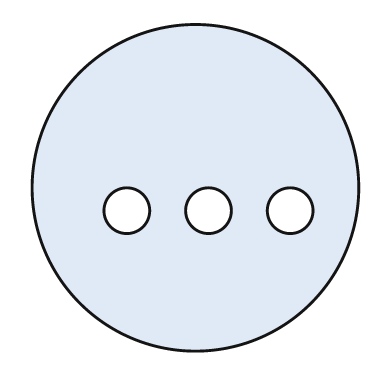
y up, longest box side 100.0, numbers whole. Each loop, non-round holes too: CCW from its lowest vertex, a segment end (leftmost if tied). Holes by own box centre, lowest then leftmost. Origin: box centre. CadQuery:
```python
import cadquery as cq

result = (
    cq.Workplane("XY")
    .moveTo(0.0, 0.0)
    .circle(50.0)
    .moveTo(-21.0, -7.0)
    .circle(7.0)
    .moveTo(4.0, -7.0)
    .circle(7.0)
    .moveTo(29.0, -7.0)
    .circle(7.0)
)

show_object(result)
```